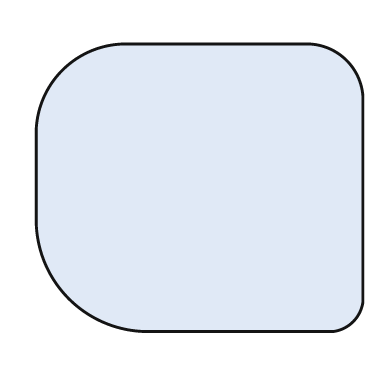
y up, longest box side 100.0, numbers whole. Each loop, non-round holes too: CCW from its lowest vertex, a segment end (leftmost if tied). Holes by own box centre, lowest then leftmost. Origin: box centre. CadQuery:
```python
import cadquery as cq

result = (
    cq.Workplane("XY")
    .moveTo(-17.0, -44.0)
    .lineTo(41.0, -44.0)
    .threePointArc((47.0, -41.0), (50.0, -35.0))
    .lineTo(50.0, 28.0)
    .threePointArc((45.0, 39.0), (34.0, 44.0))
    .lineTo(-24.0, 44.0)
    .threePointArc((-42.0, 36.0), (-50.0, 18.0))
    .lineTo(-50.0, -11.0)
    .threePointArc((-40.0, -34.0), (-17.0, -44.0))
    .close()
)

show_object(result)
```